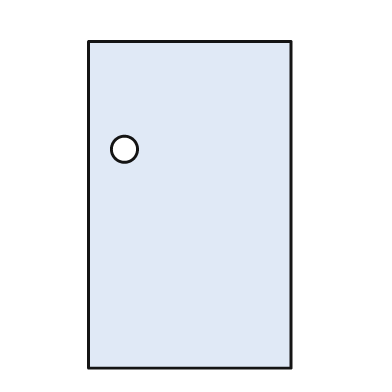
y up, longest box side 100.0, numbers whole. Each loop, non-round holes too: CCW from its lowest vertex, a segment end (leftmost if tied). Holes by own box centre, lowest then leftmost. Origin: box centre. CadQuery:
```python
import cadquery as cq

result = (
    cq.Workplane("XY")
    .moveTo(-31.0, -50.0)
    .lineTo(31.0, -50.0)
    .lineTo(31.0, 50.0)
    .lineTo(-31.0, 50.0)
    .close()
    .moveTo(-20.0, 17.0)
    .circle(4.0)
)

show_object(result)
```